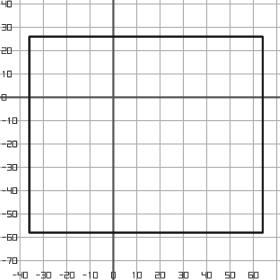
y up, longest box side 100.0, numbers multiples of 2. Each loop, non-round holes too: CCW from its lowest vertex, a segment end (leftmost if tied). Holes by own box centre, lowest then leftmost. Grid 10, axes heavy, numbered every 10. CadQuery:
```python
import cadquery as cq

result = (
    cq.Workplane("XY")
    .moveTo(-36.0, -58.0)
    .lineTo(64.0, -58.0)
    .lineTo(64.0, 26.0)
    .lineTo(-36.0, 26.0)
    .close()
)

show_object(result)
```